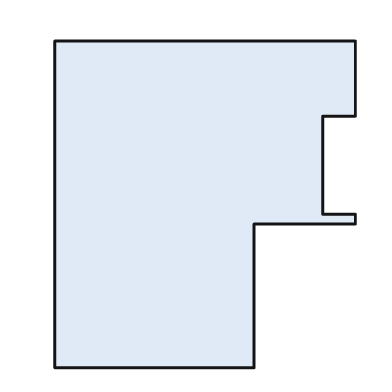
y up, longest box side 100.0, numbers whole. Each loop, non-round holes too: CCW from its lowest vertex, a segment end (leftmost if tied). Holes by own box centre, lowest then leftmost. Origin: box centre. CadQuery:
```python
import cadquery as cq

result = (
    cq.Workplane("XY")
    .moveTo(-46.0, -50.0)
    .lineTo(15.0, -50.0)
    .lineTo(15.0, -6.0)
    .lineTo(46.0, -6.0)
    .lineTo(46.0, -3.0)
    .lineTo(36.0, -3.0)
    .lineTo(36.0, 27.0)
    .lineTo(46.0, 27.0)
    .lineTo(46.0, 50.0)
    .lineTo(-46.0, 50.0)
    .close()
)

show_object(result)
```